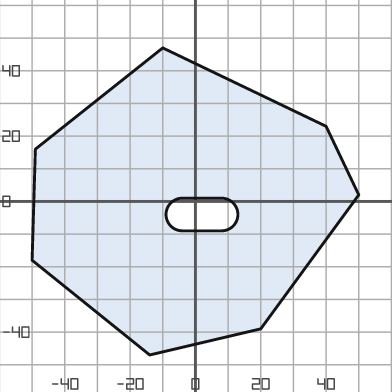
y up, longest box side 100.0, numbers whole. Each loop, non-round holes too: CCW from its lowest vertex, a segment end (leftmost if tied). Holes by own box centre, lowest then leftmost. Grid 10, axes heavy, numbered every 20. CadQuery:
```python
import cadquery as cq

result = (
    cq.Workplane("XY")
    .moveTo(-14.0, -47.0)
    .lineTo(20.0, -39.0)
    .lineTo(50.0, 2.0)
    .lineTo(40.0, 23.0)
    .lineTo(-10.0, 47.0)
    .lineTo(-49.0, 16.0)
    .lineTo(-50.0, -18.0)
    .close()
    .moveTo(-4.0, -9.0)
    .lineTo(8.0, -9.0)
    .threePointArc((13.0, -4.0), (8.0, 1.0))
    .lineTo(-4.0, 1.0)
    .threePointArc((-9.0, -4.0), (-4.0, -9.0))
    .close()
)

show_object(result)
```